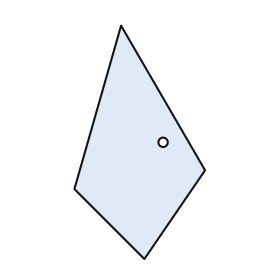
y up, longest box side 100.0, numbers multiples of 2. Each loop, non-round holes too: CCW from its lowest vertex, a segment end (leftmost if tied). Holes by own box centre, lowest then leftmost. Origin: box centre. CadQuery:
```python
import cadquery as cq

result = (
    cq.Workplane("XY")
    .moveTo(2.0, -50.0)
    .lineTo(28.0, -12.0)
    .lineTo(-8.0, 50.0)
    .lineTo(-28.0, -20.0)
    .close()
    .moveTo(10.0, 0.0)
    .circle(2.0)
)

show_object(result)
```